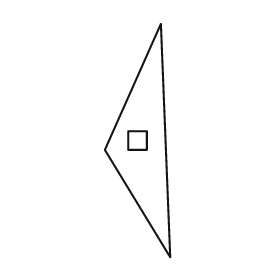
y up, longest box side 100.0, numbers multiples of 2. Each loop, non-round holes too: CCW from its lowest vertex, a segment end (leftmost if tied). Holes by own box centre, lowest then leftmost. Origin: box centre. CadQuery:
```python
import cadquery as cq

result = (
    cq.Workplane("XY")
    .moveTo(14.0, -50.0)
    .lineTo(10.0, 50.0)
    .lineTo(-14.0, -4.0)
    .close()
    .moveTo(-4.0, -4.0)
    .lineTo(4.0, -4.0)
    .lineTo(4.0, 4.0)
    .lineTo(-4.0, 4.0)
    .close()
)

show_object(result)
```